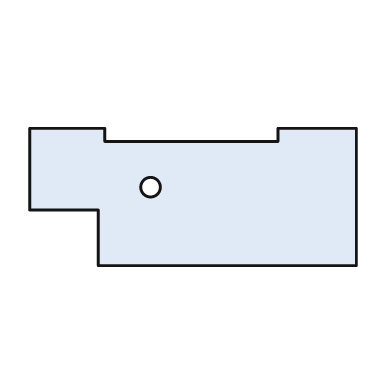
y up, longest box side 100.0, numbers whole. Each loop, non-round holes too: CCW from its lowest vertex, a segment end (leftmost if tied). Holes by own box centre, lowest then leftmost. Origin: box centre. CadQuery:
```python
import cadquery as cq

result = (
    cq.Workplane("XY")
    .moveTo(-29.0, -21.0)
    .lineTo(50.0, -21.0)
    .lineTo(50.0, 21.0)
    .lineTo(26.0, 21.0)
    .lineTo(26.0, 17.0)
    .lineTo(-27.0, 17.0)
    .lineTo(-27.0, 21.0)
    .lineTo(-50.0, 21.0)
    .lineTo(-50.0, -4.0)
    .lineTo(-29.0, -4.0)
    .close()
    .moveTo(-13.0, 3.0)
    .circle(3.0)
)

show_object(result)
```